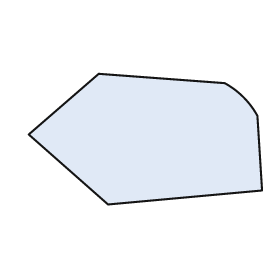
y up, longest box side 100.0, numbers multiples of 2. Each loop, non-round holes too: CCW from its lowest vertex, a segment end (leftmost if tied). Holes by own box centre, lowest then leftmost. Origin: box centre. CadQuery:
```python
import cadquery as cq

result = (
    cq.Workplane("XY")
    .moveTo(-16.0, -28.0)
    .lineTo(50.0, -22.0)
    .lineTo(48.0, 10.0)
    .threePointArc((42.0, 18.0), (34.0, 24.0))
    .lineTo(-20.0, 28.0)
    .lineTo(-50.0, 2.0)
    .close()
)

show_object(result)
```